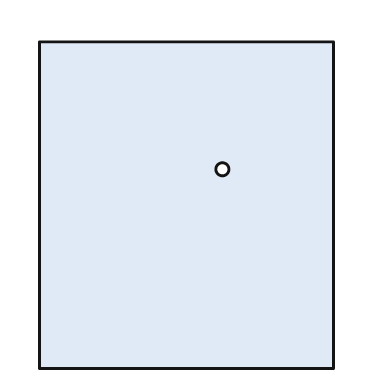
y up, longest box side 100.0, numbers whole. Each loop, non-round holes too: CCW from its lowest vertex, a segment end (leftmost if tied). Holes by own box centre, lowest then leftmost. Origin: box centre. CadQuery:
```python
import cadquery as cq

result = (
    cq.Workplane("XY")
    .moveTo(-45.0, -50.0)
    .lineTo(45.0, -50.0)
    .lineTo(45.0, 50.0)
    .lineTo(-45.0, 50.0)
    .close()
    .moveTo(11.0, 11.0)
    .circle(2.0)
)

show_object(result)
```